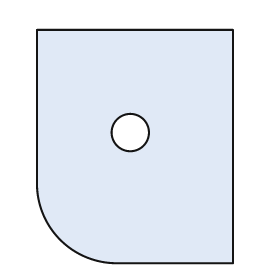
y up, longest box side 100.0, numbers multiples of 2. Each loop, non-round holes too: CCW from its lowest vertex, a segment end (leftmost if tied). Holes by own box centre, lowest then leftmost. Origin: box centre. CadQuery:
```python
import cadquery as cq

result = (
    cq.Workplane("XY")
    .moveTo(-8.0, -50.0)
    .lineTo(42.0, -50.0)
    .lineTo(42.0, 50.0)
    .lineTo(-42.0, 50.0)
    .lineTo(-42.0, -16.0)
    .threePointArc((-32.0, -40.0), (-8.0, -50.0))
    .close()
    .moveTo(-2.0, 6.0)
    .circle(8.0)
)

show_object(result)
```